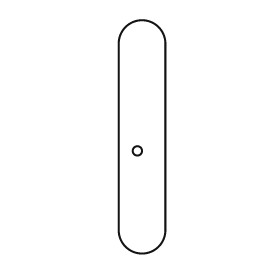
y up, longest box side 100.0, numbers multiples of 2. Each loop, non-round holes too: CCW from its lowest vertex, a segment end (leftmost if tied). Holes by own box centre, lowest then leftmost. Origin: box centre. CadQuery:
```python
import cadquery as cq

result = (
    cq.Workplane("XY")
    .moveTo(-10.0, -40.0)
    .threePointArc((0.0, -50.0), (10.0, -40.0))
    .lineTo(10.0, 40.0)
    .threePointArc((0.0, 50.0), (-10.0, 40.0))
    .close()
    .moveTo(-2.0, -6.0)
    .circle(2.0)
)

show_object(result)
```